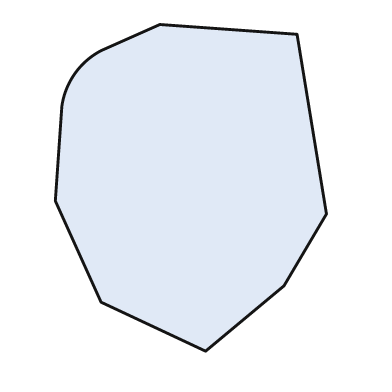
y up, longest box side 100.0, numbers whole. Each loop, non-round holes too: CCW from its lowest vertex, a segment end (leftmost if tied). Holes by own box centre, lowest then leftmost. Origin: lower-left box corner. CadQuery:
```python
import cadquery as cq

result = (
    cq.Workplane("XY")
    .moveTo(46.0, 0.0)
    .lineTo(70.0, 20.0)
    .lineTo(83.0, 42.0)
    .lineTo(74.0, 97.0)
    .lineTo(32.0, 100.0)
    .lineTo(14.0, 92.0)
    .threePointArc((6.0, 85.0), (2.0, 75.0))
    .lineTo(0.0, 46.0)
    .lineTo(14.0, 15.0)
    .close()
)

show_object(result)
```